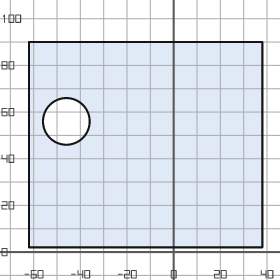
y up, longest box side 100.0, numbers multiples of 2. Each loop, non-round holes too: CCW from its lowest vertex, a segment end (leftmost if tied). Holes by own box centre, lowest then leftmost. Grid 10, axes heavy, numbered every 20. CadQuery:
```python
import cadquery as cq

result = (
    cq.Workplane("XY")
    .moveTo(-62.0, 2.0)
    .lineTo(38.0, 2.0)
    .lineTo(38.0, 90.0)
    .lineTo(-62.0, 90.0)
    .close()
    .moveTo(-46.0, 56.0)
    .circle(10.0)
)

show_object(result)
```